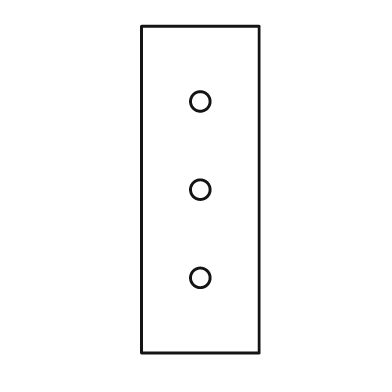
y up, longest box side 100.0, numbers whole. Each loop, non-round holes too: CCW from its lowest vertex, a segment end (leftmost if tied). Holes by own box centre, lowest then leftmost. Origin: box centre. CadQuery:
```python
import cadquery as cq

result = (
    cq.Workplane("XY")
    .moveTo(-18.0, -50.0)
    .lineTo(18.0, -50.0)
    .lineTo(18.0, 50.0)
    .lineTo(-18.0, 50.0)
    .close()
    .moveTo(0.0, -27.0)
    .circle(3.0)
    .moveTo(0.0, 0.0)
    .circle(3.0)
    .moveTo(0.0, 27.0)
    .circle(3.0)
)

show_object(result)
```